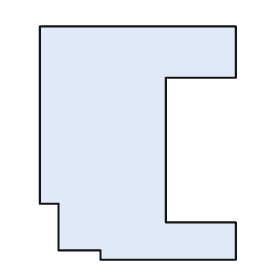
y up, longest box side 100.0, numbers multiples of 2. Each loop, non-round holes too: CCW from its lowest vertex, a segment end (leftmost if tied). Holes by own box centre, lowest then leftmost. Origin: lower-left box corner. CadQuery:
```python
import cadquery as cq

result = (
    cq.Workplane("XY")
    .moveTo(26.0, 0.0)
    .lineTo(84.0, 0.0)
    .lineTo(84.0, 16.0)
    .lineTo(54.0, 16.0)
    .lineTo(54.0, 78.0)
    .lineTo(84.0, 78.0)
    .lineTo(84.0, 100.0)
    .lineTo(0.0, 100.0)
    .lineTo(0.0, 24.0)
    .lineTo(8.0, 24.0)
    .lineTo(8.0, 4.0)
    .lineTo(26.0, 4.0)
    .close()
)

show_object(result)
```